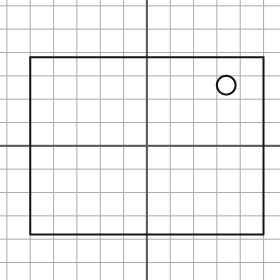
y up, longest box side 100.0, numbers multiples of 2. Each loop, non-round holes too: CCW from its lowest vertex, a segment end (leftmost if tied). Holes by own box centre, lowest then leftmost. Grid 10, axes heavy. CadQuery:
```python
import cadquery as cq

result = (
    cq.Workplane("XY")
    .moveTo(-50.0, -38.0)
    .lineTo(50.0, -38.0)
    .lineTo(50.0, 38.0)
    .lineTo(-50.0, 38.0)
    .close()
    .moveTo(34.0, 26.0)
    .circle(4.0)
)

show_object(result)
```